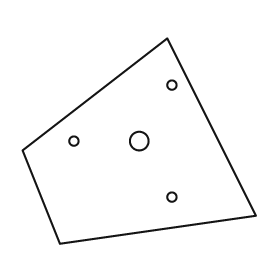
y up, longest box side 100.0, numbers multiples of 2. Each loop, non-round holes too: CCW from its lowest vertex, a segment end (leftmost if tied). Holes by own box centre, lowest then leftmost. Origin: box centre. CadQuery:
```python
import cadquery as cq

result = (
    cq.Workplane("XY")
    .moveTo(-34.0, -44.0)
    .lineTo(50.0, -32.0)
    .lineTo(12.0, 44.0)
    .lineTo(-50.0, -4.0)
    .close()
    .moveTo(14.0, -24.0)
    .circle(2.0)
    .moveTo(-28.0, 0.0)
    .circle(2.0)
    .moveTo(0.0, 0.0)
    .circle(4.0)
    .moveTo(14.0, 24.0)
    .circle(2.0)
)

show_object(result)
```